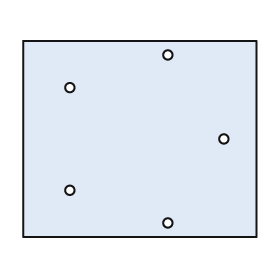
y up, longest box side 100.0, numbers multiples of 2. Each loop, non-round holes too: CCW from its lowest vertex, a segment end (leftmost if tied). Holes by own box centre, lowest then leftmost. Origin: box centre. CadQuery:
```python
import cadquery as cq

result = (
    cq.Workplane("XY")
    .moveTo(-50.0, -42.0)
    .lineTo(50.0, -42.0)
    .lineTo(50.0, 42.0)
    .lineTo(-50.0, 42.0)
    .close()
    .moveTo(12.0, -36.0)
    .circle(2.0)
    .moveTo(-30.0, -22.0)
    .circle(2.0)
    .moveTo(36.0, 0.0)
    .circle(2.0)
    .moveTo(-30.0, 22.0)
    .circle(2.0)
    .moveTo(12.0, 36.0)
    .circle(2.0)
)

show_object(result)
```